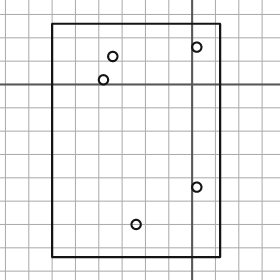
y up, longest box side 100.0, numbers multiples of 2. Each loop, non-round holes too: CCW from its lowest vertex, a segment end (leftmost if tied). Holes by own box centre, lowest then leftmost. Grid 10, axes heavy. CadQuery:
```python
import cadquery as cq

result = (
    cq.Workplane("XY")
    .moveTo(-60.0, -74.0)
    .lineTo(12.0, -74.0)
    .lineTo(12.0, 26.0)
    .lineTo(-60.0, 26.0)
    .close()
    .moveTo(-24.0, -60.0)
    .circle(2.0)
    .moveTo(2.0, -44.0)
    .circle(2.0)
    .moveTo(-38.0, 2.0)
    .circle(2.0)
    .moveTo(-34.0, 12.0)
    .circle(2.0)
    .moveTo(2.0, 16.0)
    .circle(2.0)
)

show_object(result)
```